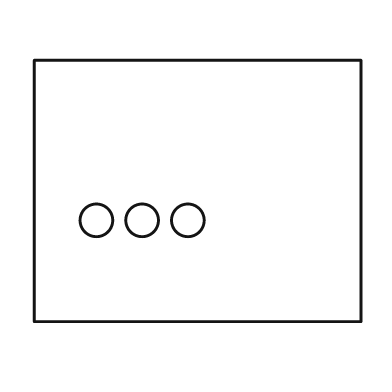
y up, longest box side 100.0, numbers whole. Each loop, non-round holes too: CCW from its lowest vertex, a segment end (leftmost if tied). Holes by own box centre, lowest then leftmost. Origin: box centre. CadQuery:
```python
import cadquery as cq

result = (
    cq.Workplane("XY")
    .moveTo(-50.0, -40.0)
    .lineTo(50.0, -40.0)
    .lineTo(50.0, 40.0)
    .lineTo(-50.0, 40.0)
    .close()
    .moveTo(-31.0, -9.0)
    .circle(5.0)
    .moveTo(-17.0, -9.0)
    .circle(5.0)
    .moveTo(-3.0, -9.0)
    .circle(5.0)
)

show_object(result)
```